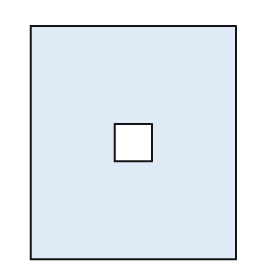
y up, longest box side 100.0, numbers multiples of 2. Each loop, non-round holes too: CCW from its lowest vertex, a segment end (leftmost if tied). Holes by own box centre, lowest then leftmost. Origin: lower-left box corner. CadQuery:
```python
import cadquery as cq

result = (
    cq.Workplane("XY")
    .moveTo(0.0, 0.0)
    .lineTo(88.0, 0.0)
    .lineTo(88.0, 100.0)
    .lineTo(0.0, 100.0)
    .close()
    .moveTo(36.0, 42.0)
    .lineTo(52.0, 42.0)
    .lineTo(52.0, 58.0)
    .lineTo(36.0, 58.0)
    .close()
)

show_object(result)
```